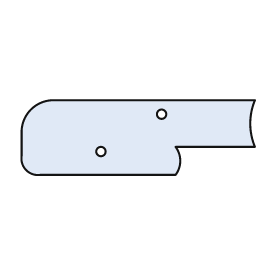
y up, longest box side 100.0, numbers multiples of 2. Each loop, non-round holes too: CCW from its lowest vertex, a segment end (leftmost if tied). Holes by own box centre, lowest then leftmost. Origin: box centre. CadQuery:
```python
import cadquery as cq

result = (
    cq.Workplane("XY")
    .moveTo(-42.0, -16.0)
    .lineTo(16.0, -16.0)
    .threePointArc((18.0, -10.0), (16.0, -4.0))
    .lineTo(50.0, -4.0)
    .threePointArc((48.0, 6.0), (50.0, 16.0))
    .lineTo(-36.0, 16.0)
    .threePointArc((-46.0, 12.0), (-50.0, 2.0))
    .lineTo(-50.0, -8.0)
    .threePointArc((-48.0, -14.0), (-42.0, -16.0))
    .close()
    .moveTo(-16.0, -6.0)
    .circle(2.0)
    .moveTo(10.0, 10.0)
    .circle(2.0)
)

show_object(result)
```